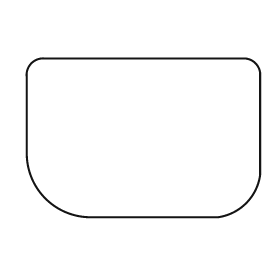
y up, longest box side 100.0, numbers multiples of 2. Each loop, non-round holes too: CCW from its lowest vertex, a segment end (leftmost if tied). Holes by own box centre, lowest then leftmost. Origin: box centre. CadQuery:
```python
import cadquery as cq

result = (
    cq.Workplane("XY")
    .moveTo(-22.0, -34.0)
    .lineTo(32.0, -34.0)
    .threePointArc((44.0, -28.0), (50.0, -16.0))
    .lineTo(50.0, 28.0)
    .threePointArc((48.0, 32.0), (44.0, 34.0))
    .lineTo(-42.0, 34.0)
    .threePointArc((-48.0, 32.0), (-50.0, 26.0))
    .lineTo(-50.0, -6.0)
    .threePointArc((-42.0, -26.0), (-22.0, -34.0))
    .close()
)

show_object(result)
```